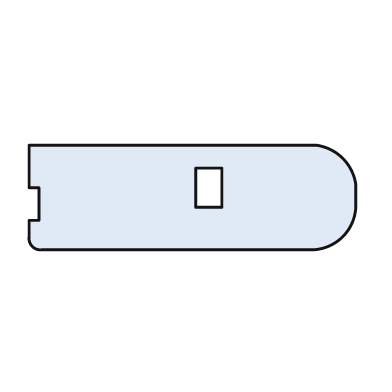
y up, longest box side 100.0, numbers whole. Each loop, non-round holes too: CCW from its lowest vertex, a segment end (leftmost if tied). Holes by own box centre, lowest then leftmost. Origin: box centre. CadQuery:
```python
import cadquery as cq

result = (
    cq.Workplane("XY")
    .moveTo(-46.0, -16.0)
    .lineTo(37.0, -16.0)
    .threePointArc((46.0, -12.0), (50.0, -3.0))
    .lineTo(50.0, 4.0)
    .threePointArc((46.0, 12.0), (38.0, 16.0))
    .lineTo(-50.0, 16.0)
    .lineTo(-50.0, 3.0)
    .lineTo(-47.0, 3.0)
    .lineTo(-47.0, -7.0)
    .lineTo(-50.0, -7.0)
    .lineTo(-50.0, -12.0)
    .threePointArc((-49.0, -15.0), (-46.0, -16.0))
    .close()
    .moveTo(1.0, -3.0)
    .lineTo(9.0, -3.0)
    .lineTo(9.0, 9.0)
    .lineTo(1.0, 9.0)
    .close()
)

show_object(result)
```